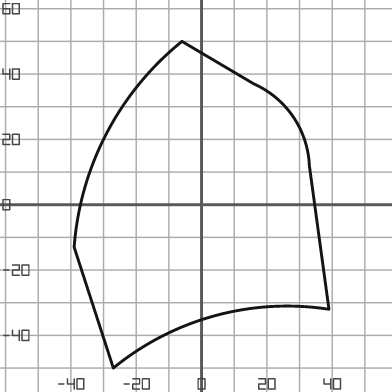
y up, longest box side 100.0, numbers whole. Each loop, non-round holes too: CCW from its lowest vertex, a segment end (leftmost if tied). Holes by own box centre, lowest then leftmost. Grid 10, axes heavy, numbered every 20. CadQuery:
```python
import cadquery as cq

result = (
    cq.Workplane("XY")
    .moveTo(-27.0, -50.0)
    .threePointArc((4.0, -34.0), (39.0, -32.0))
    .lineTo(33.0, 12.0)
    .threePointArc((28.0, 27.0), (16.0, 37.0))
    .lineTo(-6.0, 50.0)
    .threePointArc((-29.0, 22.0), (-39.0, -13.0))
    .close()
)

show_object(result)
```